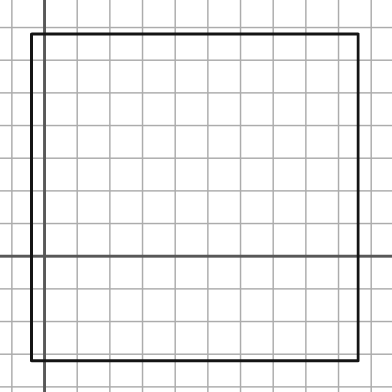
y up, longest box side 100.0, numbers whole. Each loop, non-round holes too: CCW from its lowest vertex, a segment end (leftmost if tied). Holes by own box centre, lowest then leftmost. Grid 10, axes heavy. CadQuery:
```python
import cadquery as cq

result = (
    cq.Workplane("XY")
    .moveTo(-4.0, -32.0)
    .lineTo(96.0, -32.0)
    .lineTo(96.0, 68.0)
    .lineTo(-4.0, 68.0)
    .close()
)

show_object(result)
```